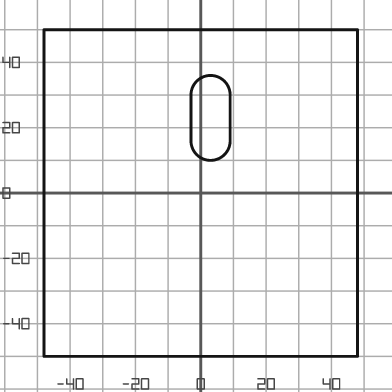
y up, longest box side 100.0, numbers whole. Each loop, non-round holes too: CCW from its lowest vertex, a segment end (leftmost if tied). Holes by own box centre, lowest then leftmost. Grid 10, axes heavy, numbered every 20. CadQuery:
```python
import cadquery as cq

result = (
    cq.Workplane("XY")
    .moveTo(-48.0, -50.0)
    .lineTo(48.0, -50.0)
    .lineTo(48.0, 50.0)
    .lineTo(-48.0, 50.0)
    .close()
    .moveTo(-3.0, 16.0)
    .threePointArc((3.0, 10.0), (9.0, 16.0))
    .lineTo(9.0, 30.0)
    .threePointArc((3.0, 36.0), (-3.0, 30.0))
    .close()
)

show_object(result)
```